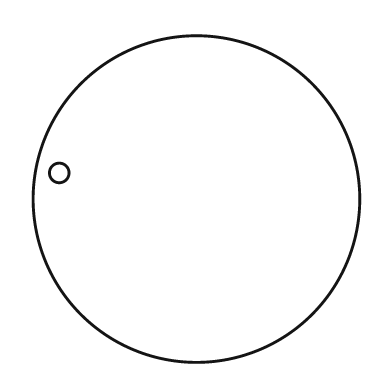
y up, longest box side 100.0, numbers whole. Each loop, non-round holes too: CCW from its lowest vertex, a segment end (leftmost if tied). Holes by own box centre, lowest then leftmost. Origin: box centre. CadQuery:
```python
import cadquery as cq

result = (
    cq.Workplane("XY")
    .moveTo(0.0, 0.0)
    .circle(50.0)
    .moveTo(-42.0, 8.0)
    .circle(3.0)
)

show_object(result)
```